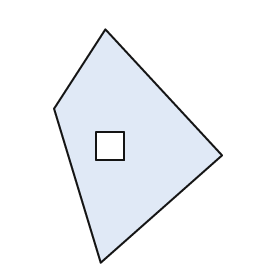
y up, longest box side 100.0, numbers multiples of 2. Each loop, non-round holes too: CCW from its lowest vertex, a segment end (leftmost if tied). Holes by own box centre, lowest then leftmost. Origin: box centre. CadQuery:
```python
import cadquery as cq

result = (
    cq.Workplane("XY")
    .moveTo(-16.0, -50.0)
    .lineTo(36.0, -4.0)
    .lineTo(-14.0, 50.0)
    .lineTo(-36.0, 16.0)
    .close()
    .moveTo(-18.0, -6.0)
    .lineTo(-6.0, -6.0)
    .lineTo(-6.0, 6.0)
    .lineTo(-18.0, 6.0)
    .close()
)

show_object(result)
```